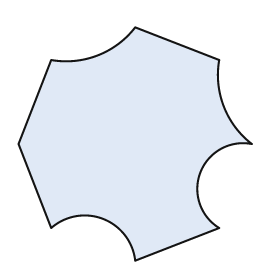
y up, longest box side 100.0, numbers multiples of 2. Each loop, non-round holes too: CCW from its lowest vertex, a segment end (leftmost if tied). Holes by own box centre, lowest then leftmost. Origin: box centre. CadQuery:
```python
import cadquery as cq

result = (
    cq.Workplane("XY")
    .moveTo(0.0, -50.0)
    .lineTo(36.0, -36.0)
    .threePointArc((28.0, -12.0), (50.0, 0.0))
    .threePointArc((38.0, 16.0), (36.0, 36.0))
    .lineTo(0.0, 50.0)
    .threePointArc((-16.0, 38.0), (-36.0, 36.0))
    .lineTo(-50.0, 0.0)
    .lineTo(-36.0, -36.0)
    .threePointArc((-14.0, -32.0), (0.0, -50.0))
    .close()
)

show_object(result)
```